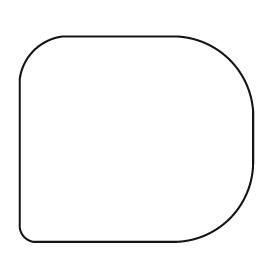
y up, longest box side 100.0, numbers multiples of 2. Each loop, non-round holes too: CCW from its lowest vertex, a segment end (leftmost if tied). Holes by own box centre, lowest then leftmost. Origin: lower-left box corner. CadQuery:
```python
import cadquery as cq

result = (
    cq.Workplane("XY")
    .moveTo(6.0, 0.0)
    .lineTo(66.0, 0.0)
    .threePointArc((90.0, 10.0), (100.0, 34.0))
    .lineTo(100.0, 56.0)
    .threePointArc((90.0, 78.0), (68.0, 88.0))
    .lineTo(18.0, 88.0)
    .threePointArc((6.0, 82.0), (0.0, 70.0))
    .lineTo(0.0, 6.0)
    .threePointArc((2.0, 2.0), (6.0, 0.0))
    .close()
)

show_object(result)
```